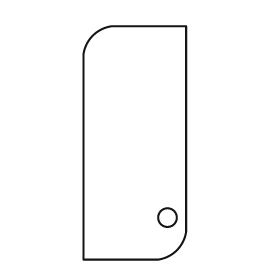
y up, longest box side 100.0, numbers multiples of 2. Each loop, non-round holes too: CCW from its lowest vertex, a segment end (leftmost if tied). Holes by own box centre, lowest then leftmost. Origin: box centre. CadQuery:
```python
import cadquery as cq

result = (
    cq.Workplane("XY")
    .moveTo(-22.0, -50.0)
    .lineTo(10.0, -50.0)
    .threePointArc((18.0, -46.0), (22.0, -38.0))
    .lineTo(22.0, 50.0)
    .lineTo(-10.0, 50.0)
    .threePointArc((-18.0, 46.0), (-22.0, 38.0))
    .close()
    .moveTo(14.0, -32.0)
    .circle(4.0)
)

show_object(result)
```